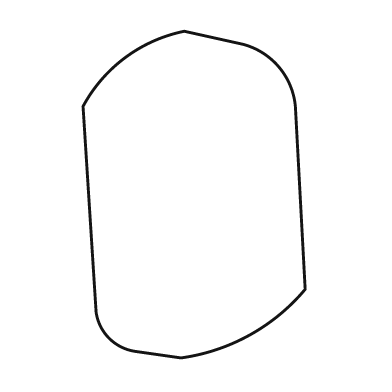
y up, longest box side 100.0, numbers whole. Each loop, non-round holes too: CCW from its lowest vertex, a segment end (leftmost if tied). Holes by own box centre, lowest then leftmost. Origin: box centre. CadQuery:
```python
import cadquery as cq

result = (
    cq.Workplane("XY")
    .moveTo(-4.0, -50.0)
    .threePointArc((17.0, -43.0), (34.0, -29.0))
    .lineTo(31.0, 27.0)
    .threePointArc((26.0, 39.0), (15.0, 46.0))
    .lineTo(-3.0, 50.0)
    .threePointArc((-21.0, 42.0), (-34.0, 27.0))
    .lineTo(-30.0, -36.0)
    .threePointArc((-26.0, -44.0), (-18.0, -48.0))
    .close()
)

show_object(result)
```